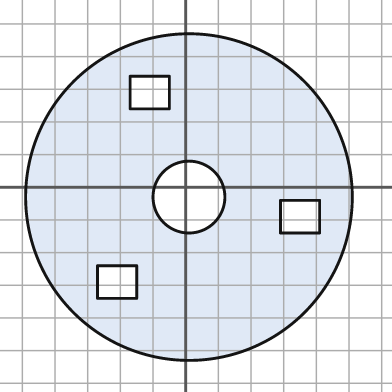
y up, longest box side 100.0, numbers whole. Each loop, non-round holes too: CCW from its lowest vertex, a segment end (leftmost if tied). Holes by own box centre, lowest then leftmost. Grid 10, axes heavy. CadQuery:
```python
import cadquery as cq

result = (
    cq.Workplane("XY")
    .moveTo(1.0, -3.0)
    .circle(50.0)
    .moveTo(-27.0, -34.0)
    .lineTo(-15.0, -34.0)
    .lineTo(-15.0, -24.0)
    .lineTo(-27.0, -24.0)
    .close()
    .moveTo(29.0, -14.0)
    .lineTo(41.0, -14.0)
    .lineTo(41.0, -4.0)
    .lineTo(29.0, -4.0)
    .close()
    .moveTo(1.0, -3.0)
    .circle(11.0)
    .moveTo(-17.0, 24.0)
    .lineTo(-5.0, 24.0)
    .lineTo(-5.0, 34.0)
    .lineTo(-17.0, 34.0)
    .close()
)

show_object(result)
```